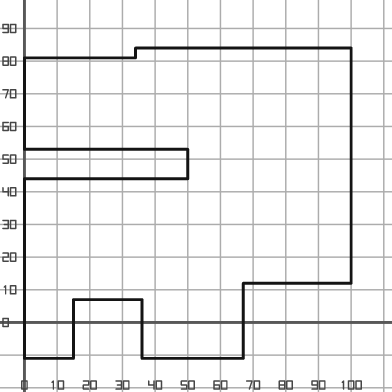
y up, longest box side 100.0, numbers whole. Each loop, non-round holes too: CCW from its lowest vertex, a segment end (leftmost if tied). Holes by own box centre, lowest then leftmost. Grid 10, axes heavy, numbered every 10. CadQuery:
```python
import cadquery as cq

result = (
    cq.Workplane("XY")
    .moveTo(0.0, -11.0)
    .lineTo(15.0, -11.0)
    .lineTo(15.0, 7.0)
    .lineTo(36.0, 7.0)
    .lineTo(36.0, -11.0)
    .lineTo(67.0, -11.0)
    .lineTo(67.0, 12.0)
    .lineTo(100.0, 12.0)
    .lineTo(100.0, 84.0)
    .lineTo(34.0, 84.0)
    .lineTo(34.0, 81.0)
    .lineTo(0.0, 81.0)
    .lineTo(0.0, 53.0)
    .lineTo(50.0, 53.0)
    .lineTo(50.0, 44.0)
    .lineTo(0.0, 44.0)
    .close()
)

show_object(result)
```